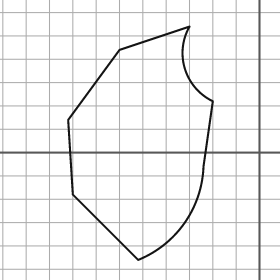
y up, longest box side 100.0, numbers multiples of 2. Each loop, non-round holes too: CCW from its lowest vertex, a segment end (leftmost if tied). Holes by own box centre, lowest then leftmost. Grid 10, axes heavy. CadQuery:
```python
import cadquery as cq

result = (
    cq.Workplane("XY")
    .moveTo(-52.0, -46.0)
    .threePointArc((-32.0, -30.0), (-24.0, -6.0))
    .lineTo(-20.0, 22.0)
    .threePointArc((-32.0, 36.0), (-30.0, 54.0))
    .lineTo(-60.0, 44.0)
    .lineTo(-82.0, 14.0)
    .lineTo(-80.0, -18.0)
    .close()
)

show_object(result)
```